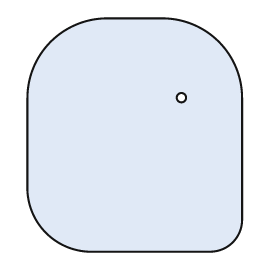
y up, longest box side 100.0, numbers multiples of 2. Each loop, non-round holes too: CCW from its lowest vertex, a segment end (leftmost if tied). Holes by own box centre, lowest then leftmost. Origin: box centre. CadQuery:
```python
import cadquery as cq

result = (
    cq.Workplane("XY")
    .moveTo(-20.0, -50.0)
    .lineTo(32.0, -50.0)
    .threePointArc((42.0, -46.0), (46.0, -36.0))
    .lineTo(46.0, 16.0)
    .threePointArc((36.0, 40.0), (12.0, 50.0))
    .lineTo(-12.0, 50.0)
    .threePointArc((-36.0, 40.0), (-46.0, 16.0))
    .lineTo(-46.0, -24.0)
    .threePointArc((-38.0, -42.0), (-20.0, -50.0))
    .close()
    .moveTo(20.0, 16.0)
    .circle(2.0)
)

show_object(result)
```